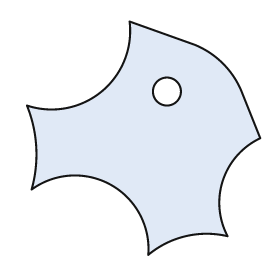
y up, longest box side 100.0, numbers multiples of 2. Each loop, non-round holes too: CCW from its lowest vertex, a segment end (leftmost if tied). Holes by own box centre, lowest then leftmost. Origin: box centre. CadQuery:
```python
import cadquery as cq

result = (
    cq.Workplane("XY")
    .moveTo(2.0, -50.0)
    .threePointArc((18.0, -42.0), (36.0, -42.0))
    .threePointArc((34.0, -18.0), (50.0, 0.0))
    .lineTo(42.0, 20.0)
    .threePointArc((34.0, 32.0), (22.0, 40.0))
    .lineTo(-6.0, 50.0)
    .threePointArc((-18.0, 20.0), (-50.0, 14.0))
    .threePointArc((-46.0, -4.0), (-48.0, -22.0))
    .threePointArc((-14.0, -20.0), (2.0, -50.0))
    .close()
    .moveTo(10.0, 20.0)
    .circle(6.0)
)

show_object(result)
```